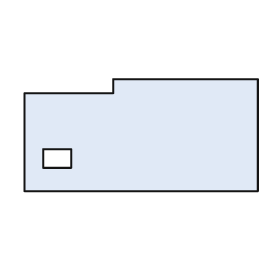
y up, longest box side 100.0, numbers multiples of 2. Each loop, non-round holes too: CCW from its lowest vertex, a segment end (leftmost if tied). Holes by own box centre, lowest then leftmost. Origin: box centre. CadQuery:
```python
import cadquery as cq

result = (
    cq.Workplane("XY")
    .moveTo(-50.0, -24.0)
    .lineTo(50.0, -24.0)
    .lineTo(50.0, 24.0)
    .lineTo(-12.0, 24.0)
    .lineTo(-12.0, 18.0)
    .lineTo(-50.0, 18.0)
    .close()
    .moveTo(-42.0, -14.0)
    .lineTo(-30.0, -14.0)
    .lineTo(-30.0, -6.0)
    .lineTo(-42.0, -6.0)
    .close()
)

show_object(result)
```